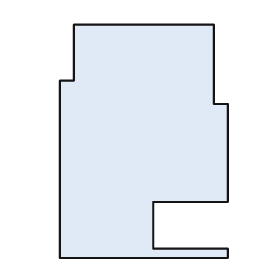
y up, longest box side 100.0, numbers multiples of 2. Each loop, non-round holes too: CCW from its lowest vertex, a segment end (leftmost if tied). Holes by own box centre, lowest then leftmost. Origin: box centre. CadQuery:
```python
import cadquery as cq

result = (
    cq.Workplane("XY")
    .moveTo(-36.0, -50.0)
    .lineTo(36.0, -50.0)
    .lineTo(36.0, -46.0)
    .lineTo(4.0, -46.0)
    .lineTo(4.0, -26.0)
    .lineTo(36.0, -26.0)
    .lineTo(36.0, 16.0)
    .lineTo(30.0, 16.0)
    .lineTo(30.0, 50.0)
    .lineTo(-30.0, 50.0)
    .lineTo(-30.0, 26.0)
    .lineTo(-36.0, 26.0)
    .close()
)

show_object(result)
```